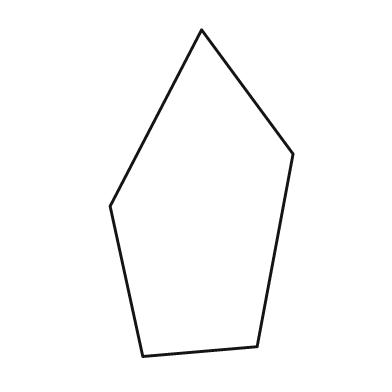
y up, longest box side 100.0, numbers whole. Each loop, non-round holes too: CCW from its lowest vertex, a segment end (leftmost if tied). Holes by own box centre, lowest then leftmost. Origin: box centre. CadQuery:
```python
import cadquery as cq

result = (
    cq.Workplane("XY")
    .moveTo(-18.0, -50.0)
    .lineTo(17.0, -47.0)
    .lineTo(28.0, 12.0)
    .lineTo(0.0, 50.0)
    .lineTo(-28.0, -4.0)
    .close()
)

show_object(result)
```